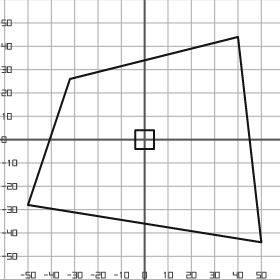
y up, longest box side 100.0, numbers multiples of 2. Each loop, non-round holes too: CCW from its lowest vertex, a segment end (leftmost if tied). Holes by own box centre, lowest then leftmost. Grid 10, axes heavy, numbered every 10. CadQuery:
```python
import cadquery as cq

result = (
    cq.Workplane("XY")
    .moveTo(50.0, -44.0)
    .lineTo(40.0, 44.0)
    .lineTo(-32.0, 26.0)
    .lineTo(-50.0, -28.0)
    .close()
    .moveTo(-4.0, -4.0)
    .lineTo(4.0, -4.0)
    .lineTo(4.0, 4.0)
    .lineTo(-4.0, 4.0)
    .close()
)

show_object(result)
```